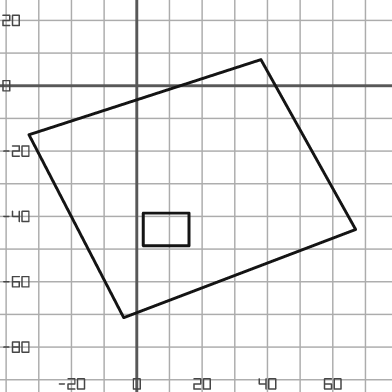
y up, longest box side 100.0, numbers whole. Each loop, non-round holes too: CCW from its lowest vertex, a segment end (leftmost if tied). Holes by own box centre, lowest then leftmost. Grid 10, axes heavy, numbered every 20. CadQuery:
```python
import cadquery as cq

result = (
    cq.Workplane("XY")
    .moveTo(-4.0, -71.0)
    .lineTo(67.0, -44.0)
    .lineTo(38.0, 8.0)
    .lineTo(-33.0, -15.0)
    .close()
    .moveTo(2.0, -49.0)
    .lineTo(16.0, -49.0)
    .lineTo(16.0, -39.0)
    .lineTo(2.0, -39.0)
    .close()
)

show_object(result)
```